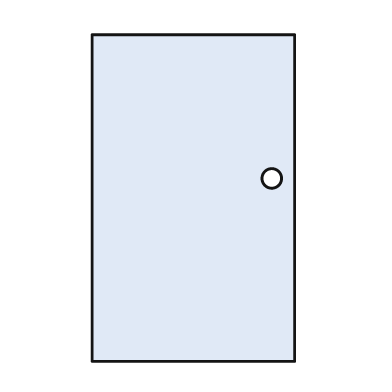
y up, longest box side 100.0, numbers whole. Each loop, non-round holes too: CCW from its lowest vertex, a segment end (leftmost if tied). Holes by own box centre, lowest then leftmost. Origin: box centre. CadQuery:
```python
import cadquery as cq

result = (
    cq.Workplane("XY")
    .moveTo(-31.0, -50.0)
    .lineTo(31.0, -50.0)
    .lineTo(31.0, 50.0)
    .lineTo(-31.0, 50.0)
    .close()
    .moveTo(24.0, 6.0)
    .circle(3.0)
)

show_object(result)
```